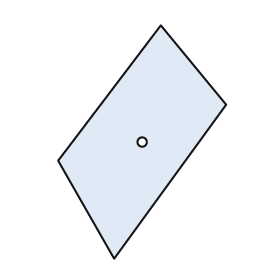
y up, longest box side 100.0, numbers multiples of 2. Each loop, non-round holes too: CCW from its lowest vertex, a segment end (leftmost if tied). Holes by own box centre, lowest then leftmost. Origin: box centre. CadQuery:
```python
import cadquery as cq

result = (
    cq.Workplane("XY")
    .moveTo(-12.0, -50.0)
    .lineTo(36.0, 16.0)
    .lineTo(8.0, 50.0)
    .lineTo(-36.0, -8.0)
    .close()
    .moveTo(0.0, 0.0)
    .circle(2.0)
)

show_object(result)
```